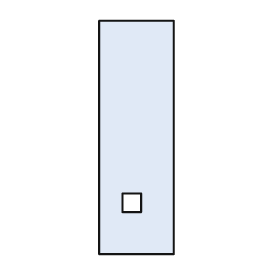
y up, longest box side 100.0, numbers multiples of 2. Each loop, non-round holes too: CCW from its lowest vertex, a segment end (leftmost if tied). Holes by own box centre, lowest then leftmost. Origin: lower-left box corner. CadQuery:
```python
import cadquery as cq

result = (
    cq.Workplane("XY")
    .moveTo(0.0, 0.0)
    .lineTo(32.0, 0.0)
    .lineTo(32.0, 100.0)
    .lineTo(0.0, 100.0)
    .close()
    .moveTo(10.0, 18.0)
    .lineTo(18.0, 18.0)
    .lineTo(18.0, 26.0)
    .lineTo(10.0, 26.0)
    .close()
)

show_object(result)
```